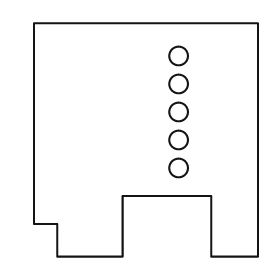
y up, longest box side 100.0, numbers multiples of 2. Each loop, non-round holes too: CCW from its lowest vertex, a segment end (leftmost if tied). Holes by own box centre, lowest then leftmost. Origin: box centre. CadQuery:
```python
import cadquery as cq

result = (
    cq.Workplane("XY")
    .moveTo(-38.0, -50.0)
    .lineTo(-10.0, -50.0)
    .lineTo(-10.0, -24.0)
    .lineTo(28.0, -24.0)
    .lineTo(28.0, -50.0)
    .lineTo(48.0, -50.0)
    .lineTo(48.0, 50.0)
    .lineTo(-48.0, 50.0)
    .lineTo(-48.0, -36.0)
    .lineTo(-38.0, -36.0)
    .close()
    .moveTo(14.0, -12.0)
    .circle(4.0)
    .moveTo(14.0, 0.0)
    .circle(4.0)
    .moveTo(14.0, 12.0)
    .circle(4.0)
    .moveTo(14.0, 24.0)
    .circle(4.0)
    .moveTo(14.0, 36.0)
    .circle(4.0)
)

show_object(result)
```